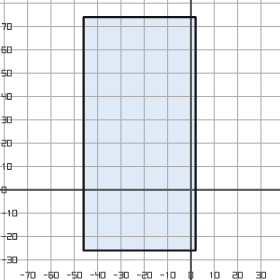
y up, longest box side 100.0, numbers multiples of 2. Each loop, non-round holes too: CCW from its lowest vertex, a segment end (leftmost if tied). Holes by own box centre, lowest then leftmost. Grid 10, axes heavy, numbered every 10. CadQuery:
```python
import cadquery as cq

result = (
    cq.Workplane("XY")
    .moveTo(-46.0, -26.0)
    .lineTo(2.0, -26.0)
    .lineTo(2.0, 74.0)
    .lineTo(-46.0, 74.0)
    .close()
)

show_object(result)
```